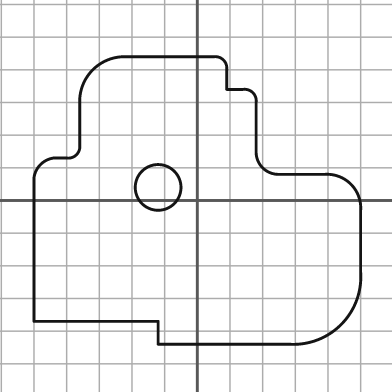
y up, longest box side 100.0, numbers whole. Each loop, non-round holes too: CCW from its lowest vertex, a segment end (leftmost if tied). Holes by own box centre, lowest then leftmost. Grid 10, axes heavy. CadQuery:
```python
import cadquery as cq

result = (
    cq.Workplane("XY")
    .moveTo(-12.0, -44.0)
    .lineTo(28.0, -44.0)
    .threePointArc((44.0, -38.0), (50.0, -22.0))
    .lineTo(50.0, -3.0)
    .threePointArc((47.0, 5.0), (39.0, 8.0))
    .lineTo(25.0, 8.0)
    .threePointArc((20.0, 10.0), (18.0, 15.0))
    .lineTo(18.0, 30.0)
    .threePointArc((17.0, 33.0), (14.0, 34.0))
    .lineTo(9.0, 34.0)
    .lineTo(9.0, 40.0)
    .threePointArc((8.0, 43.0), (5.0, 44.0))
    .lineTo(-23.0, 44.0)
    .threePointArc((-32.0, 40.0), (-36.0, 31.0))
    .lineTo(-36.0, 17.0)
    .threePointArc((-37.0, 14.0), (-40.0, 13.0))
    .lineTo(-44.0, 13.0)
    .threePointArc((-48.0, 11.0), (-50.0, 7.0))
    .lineTo(-50.0, -37.0)
    .lineTo(-12.0, -37.0)
    .close()
    .moveTo(-12.0, 4.0)
    .circle(7.0)
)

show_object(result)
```